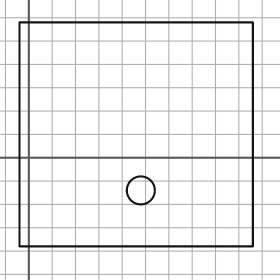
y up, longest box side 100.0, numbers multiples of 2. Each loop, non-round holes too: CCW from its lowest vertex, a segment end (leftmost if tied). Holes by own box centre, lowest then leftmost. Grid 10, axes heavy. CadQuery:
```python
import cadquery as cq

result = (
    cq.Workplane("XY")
    .moveTo(-4.0, -38.0)
    .lineTo(96.0, -38.0)
    .lineTo(96.0, 58.0)
    .lineTo(-4.0, 58.0)
    .close()
    .moveTo(48.0, -14.0)
    .circle(6.0)
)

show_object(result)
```